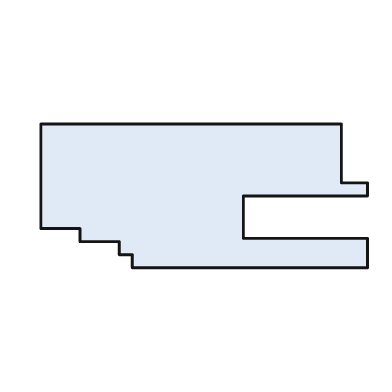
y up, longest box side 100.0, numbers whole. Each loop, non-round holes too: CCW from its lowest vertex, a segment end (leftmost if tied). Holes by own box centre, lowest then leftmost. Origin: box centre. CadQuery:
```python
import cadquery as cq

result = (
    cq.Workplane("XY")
    .moveTo(-22.0, -22.0)
    .lineTo(50.0, -22.0)
    .lineTo(50.0, -13.0)
    .lineTo(12.0, -13.0)
    .lineTo(12.0, 0.0)
    .lineTo(50.0, 0.0)
    .lineTo(50.0, 4.0)
    .lineTo(42.0, 4.0)
    .lineTo(42.0, 22.0)
    .lineTo(-50.0, 22.0)
    .lineTo(-50.0, -10.0)
    .lineTo(-38.0, -10.0)
    .lineTo(-38.0, -14.0)
    .lineTo(-26.0, -14.0)
    .lineTo(-26.0, -18.0)
    .lineTo(-22.0, -18.0)
    .close()
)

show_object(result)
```